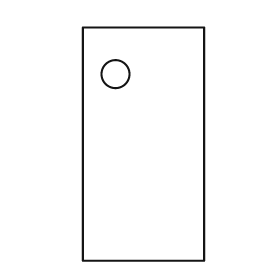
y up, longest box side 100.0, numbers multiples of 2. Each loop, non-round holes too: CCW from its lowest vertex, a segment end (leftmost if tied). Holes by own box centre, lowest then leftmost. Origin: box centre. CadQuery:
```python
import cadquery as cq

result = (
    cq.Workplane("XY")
    .moveTo(-26.0, -50.0)
    .lineTo(26.0, -50.0)
    .lineTo(26.0, 50.0)
    .lineTo(-26.0, 50.0)
    .close()
    .moveTo(-12.0, 30.0)
    .circle(6.0)
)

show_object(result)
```